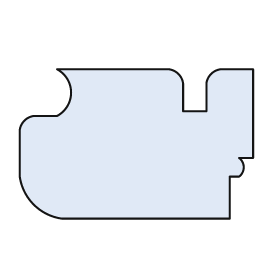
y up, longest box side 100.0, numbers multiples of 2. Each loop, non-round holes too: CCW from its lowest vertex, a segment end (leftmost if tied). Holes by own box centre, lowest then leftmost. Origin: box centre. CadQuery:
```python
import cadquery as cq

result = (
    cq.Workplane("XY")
    .moveTo(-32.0, -32.0)
    .lineTo(40.0, -32.0)
    .lineTo(40.0, -14.0)
    .lineTo(44.0, -14.0)
    .threePointArc((46.0, -10.0), (44.0, -6.0))
    .lineTo(50.0, -6.0)
    .lineTo(50.0, 32.0)
    .lineTo(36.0, 32.0)
    .threePointArc((32.0, 30.0), (30.0, 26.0))
    .lineTo(30.0, 14.0)
    .lineTo(20.0, 14.0)
    .lineTo(20.0, 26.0)
    .threePointArc((18.0, 30.0), (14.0, 32.0))
    .lineTo(-34.0, 32.0)
    .threePointArc((-28.0, 22.0), (-34.0, 12.0))
    .lineTo(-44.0, 12.0)
    .threePointArc((-48.0, 10.0), (-50.0, 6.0))
    .lineTo(-50.0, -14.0)
    .threePointArc((-44.0, -26.0), (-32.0, -32.0))
    .close()
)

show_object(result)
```